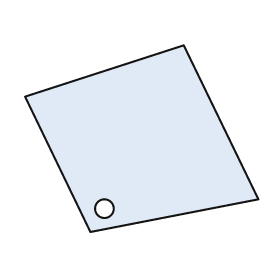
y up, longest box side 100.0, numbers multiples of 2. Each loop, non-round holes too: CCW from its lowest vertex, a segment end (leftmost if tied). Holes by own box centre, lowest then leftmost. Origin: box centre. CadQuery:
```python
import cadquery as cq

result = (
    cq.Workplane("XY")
    .moveTo(-22.0, -40.0)
    .lineTo(50.0, -26.0)
    .lineTo(18.0, 40.0)
    .lineTo(-50.0, 18.0)
    .close()
    .moveTo(-16.0, -30.0)
    .circle(4.0)
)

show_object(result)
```